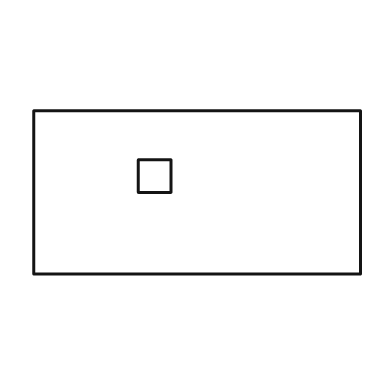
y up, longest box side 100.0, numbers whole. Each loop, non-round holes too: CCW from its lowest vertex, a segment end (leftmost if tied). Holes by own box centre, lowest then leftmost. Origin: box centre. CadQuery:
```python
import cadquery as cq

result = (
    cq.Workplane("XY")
    .moveTo(-50.0, -25.0)
    .lineTo(50.0, -25.0)
    .lineTo(50.0, 25.0)
    .lineTo(-50.0, 25.0)
    .close()
    .moveTo(-18.0, 0.0)
    .lineTo(-8.0, 0.0)
    .lineTo(-8.0, 10.0)
    .lineTo(-18.0, 10.0)
    .close()
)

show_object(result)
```